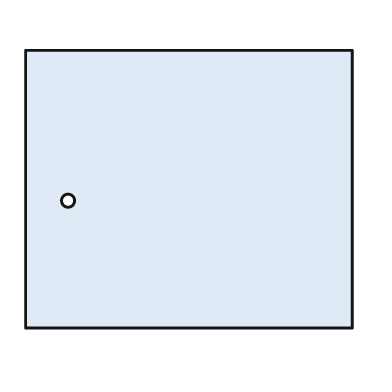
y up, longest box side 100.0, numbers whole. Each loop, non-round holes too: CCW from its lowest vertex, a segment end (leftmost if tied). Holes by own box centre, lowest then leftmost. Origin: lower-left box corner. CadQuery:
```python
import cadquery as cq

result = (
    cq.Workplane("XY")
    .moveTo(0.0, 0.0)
    .lineTo(100.0, 0.0)
    .lineTo(100.0, 85.0)
    .lineTo(0.0, 85.0)
    .close()
    .moveTo(13.0, 39.0)
    .circle(2.0)
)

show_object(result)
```